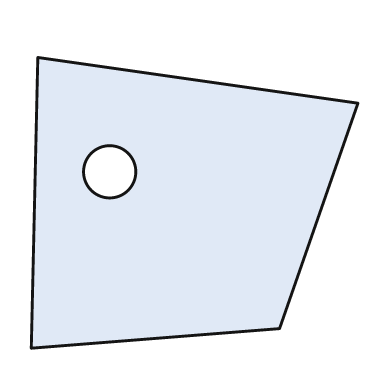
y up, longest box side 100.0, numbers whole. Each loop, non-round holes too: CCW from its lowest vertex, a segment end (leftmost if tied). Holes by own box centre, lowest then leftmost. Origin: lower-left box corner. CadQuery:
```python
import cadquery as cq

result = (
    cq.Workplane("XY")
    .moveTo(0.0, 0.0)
    .lineTo(76.0, 6.0)
    .lineTo(100.0, 75.0)
    .lineTo(2.0, 89.0)
    .close()
    .moveTo(24.0, 54.0)
    .circle(8.0)
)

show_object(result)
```